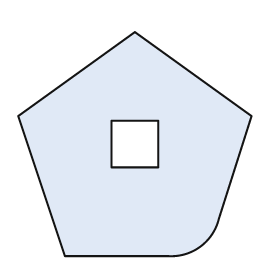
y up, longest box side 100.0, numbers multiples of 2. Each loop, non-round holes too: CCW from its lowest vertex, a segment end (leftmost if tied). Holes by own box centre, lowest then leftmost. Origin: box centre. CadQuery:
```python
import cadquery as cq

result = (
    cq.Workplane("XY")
    .moveTo(-30.0, -48.0)
    .lineTo(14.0, -48.0)
    .threePointArc((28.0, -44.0), (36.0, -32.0))
    .lineTo(50.0, 12.0)
    .lineTo(0.0, 48.0)
    .lineTo(-50.0, 12.0)
    .close()
    .moveTo(-10.0, -10.0)
    .lineTo(10.0, -10.0)
    .lineTo(10.0, 10.0)
    .lineTo(-10.0, 10.0)
    .close()
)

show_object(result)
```